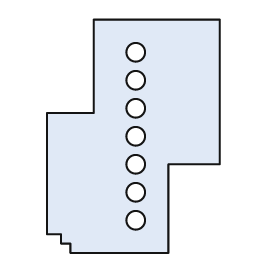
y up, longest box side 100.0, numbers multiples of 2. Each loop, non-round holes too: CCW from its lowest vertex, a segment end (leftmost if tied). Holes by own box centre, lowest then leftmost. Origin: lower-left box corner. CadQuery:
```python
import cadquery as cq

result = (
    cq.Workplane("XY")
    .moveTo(10.0, 0.0)
    .lineTo(52.0, 0.0)
    .lineTo(52.0, 38.0)
    .lineTo(74.0, 38.0)
    .lineTo(74.0, 100.0)
    .lineTo(20.0, 100.0)
    .lineTo(20.0, 60.0)
    .lineTo(0.0, 60.0)
    .lineTo(0.0, 8.0)
    .lineTo(6.0, 8.0)
    .lineTo(6.0, 4.0)
    .lineTo(10.0, 4.0)
    .close()
    .moveTo(38.0, 14.0)
    .circle(4.0)
    .moveTo(38.0, 26.0)
    .circle(4.0)
    .moveTo(38.0, 38.0)
    .circle(4.0)
    .moveTo(38.0, 50.0)
    .circle(4.0)
    .moveTo(38.0, 62.0)
    .circle(4.0)
    .moveTo(38.0, 74.0)
    .circle(4.0)
    .moveTo(38.0, 86.0)
    .circle(4.0)
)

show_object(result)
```